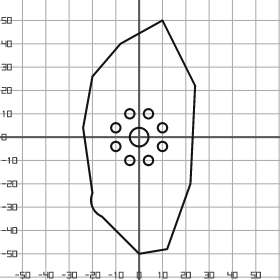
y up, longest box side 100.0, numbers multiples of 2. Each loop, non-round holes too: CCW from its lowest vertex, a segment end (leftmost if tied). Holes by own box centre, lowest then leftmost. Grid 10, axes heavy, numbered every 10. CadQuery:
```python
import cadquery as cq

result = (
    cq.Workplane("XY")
    .moveTo(0.0, -50.0)
    .lineTo(12.0, -48.0)
    .lineTo(22.0, -20.0)
    .lineTo(24.0, 22.0)
    .lineTo(10.0, 50.0)
    .lineTo(-8.0, 40.0)
    .lineTo(-20.0, 26.0)
    .lineTo(-24.0, 4.0)
    .lineTo(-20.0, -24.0)
    .threePointArc((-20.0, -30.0), (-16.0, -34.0))
    .close()
    .moveTo(-4.0, -10.0)
    .circle(2.0)
    .moveTo(4.0, -10.0)
    .circle(2.0)
    .moveTo(-10.0, -4.0)
    .circle(2.0)
    .moveTo(10.0, -4.0)
    .circle(2.0)
    .moveTo(0.0, 0.0)
    .circle(4.0)
    .moveTo(-10.0, 4.0)
    .circle(2.0)
    .moveTo(10.0, 4.0)
    .circle(2.0)
    .moveTo(-4.0, 10.0)
    .circle(2.0)
    .moveTo(4.0, 10.0)
    .circle(2.0)
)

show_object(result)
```